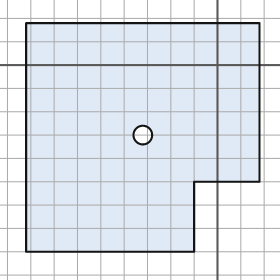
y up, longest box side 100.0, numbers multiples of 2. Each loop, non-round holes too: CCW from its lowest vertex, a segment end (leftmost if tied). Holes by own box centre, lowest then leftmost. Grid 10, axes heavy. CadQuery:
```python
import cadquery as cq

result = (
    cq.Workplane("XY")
    .moveTo(-82.0, -80.0)
    .lineTo(-10.0, -80.0)
    .lineTo(-10.0, -50.0)
    .lineTo(18.0, -50.0)
    .lineTo(18.0, 18.0)
    .lineTo(-82.0, 18.0)
    .close()
    .moveTo(-32.0, -30.0)
    .circle(4.0)
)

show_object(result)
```